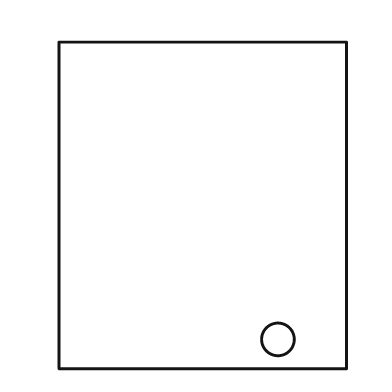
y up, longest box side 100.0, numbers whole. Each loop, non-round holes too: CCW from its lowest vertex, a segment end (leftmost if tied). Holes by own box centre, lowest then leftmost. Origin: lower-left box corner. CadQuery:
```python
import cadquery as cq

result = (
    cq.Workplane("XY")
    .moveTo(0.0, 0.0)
    .lineTo(88.0, 0.0)
    .lineTo(88.0, 100.0)
    .lineTo(0.0, 100.0)
    .close()
    .moveTo(67.0, 9.0)
    .circle(5.0)
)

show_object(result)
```